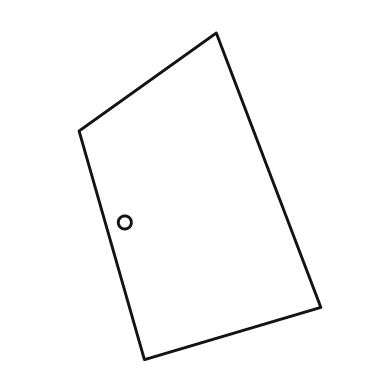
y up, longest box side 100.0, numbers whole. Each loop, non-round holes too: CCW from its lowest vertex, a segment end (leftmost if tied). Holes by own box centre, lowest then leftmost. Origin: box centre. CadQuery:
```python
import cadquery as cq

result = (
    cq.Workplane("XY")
    .moveTo(-17.0, -50.0)
    .lineTo(37.0, -34.0)
    .lineTo(5.0, 50.0)
    .lineTo(-37.0, 20.0)
    .close()
    .moveTo(-23.0, -8.0)
    .circle(2.0)
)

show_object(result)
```